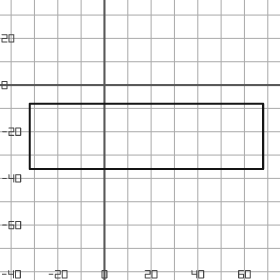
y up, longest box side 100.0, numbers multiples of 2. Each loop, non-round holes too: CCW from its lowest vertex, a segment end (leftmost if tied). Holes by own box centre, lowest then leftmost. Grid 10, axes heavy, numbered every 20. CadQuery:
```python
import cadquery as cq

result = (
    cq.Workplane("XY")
    .moveTo(-32.0, -36.0)
    .lineTo(68.0, -36.0)
    .lineTo(68.0, -8.0)
    .lineTo(-32.0, -8.0)
    .close()
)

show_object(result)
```